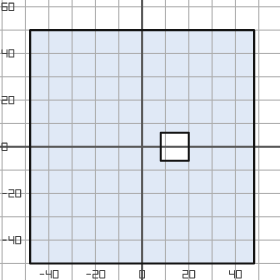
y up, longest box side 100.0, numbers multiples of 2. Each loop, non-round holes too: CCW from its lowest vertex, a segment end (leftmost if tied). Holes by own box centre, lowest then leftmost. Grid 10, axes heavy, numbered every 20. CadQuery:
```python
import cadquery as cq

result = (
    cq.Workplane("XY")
    .moveTo(-48.0, -50.0)
    .lineTo(48.0, -50.0)
    .lineTo(48.0, 50.0)
    .lineTo(-48.0, 50.0)
    .close()
    .moveTo(8.0, -6.0)
    .lineTo(20.0, -6.0)
    .lineTo(20.0, 6.0)
    .lineTo(8.0, 6.0)
    .close()
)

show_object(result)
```